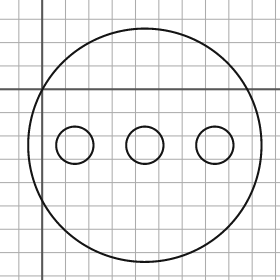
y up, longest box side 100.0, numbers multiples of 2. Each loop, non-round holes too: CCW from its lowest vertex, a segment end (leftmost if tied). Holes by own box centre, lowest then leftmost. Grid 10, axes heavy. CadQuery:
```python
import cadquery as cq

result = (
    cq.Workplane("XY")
    .moveTo(44.0, -24.0)
    .circle(50.0)
    .moveTo(14.0, -24.0)
    .circle(8.0)
    .moveTo(44.0, -24.0)
    .circle(8.0)
    .moveTo(74.0, -24.0)
    .circle(8.0)
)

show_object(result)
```